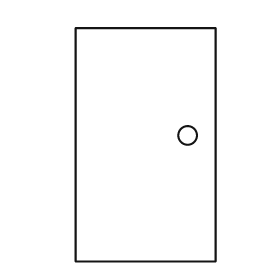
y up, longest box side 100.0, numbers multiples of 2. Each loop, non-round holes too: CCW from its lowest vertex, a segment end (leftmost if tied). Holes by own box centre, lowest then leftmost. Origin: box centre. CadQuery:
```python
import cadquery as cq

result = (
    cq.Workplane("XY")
    .moveTo(-30.0, -50.0)
    .lineTo(30.0, -50.0)
    .lineTo(30.0, 50.0)
    .lineTo(-30.0, 50.0)
    .close()
    .moveTo(18.0, 4.0)
    .circle(4.0)
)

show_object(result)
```